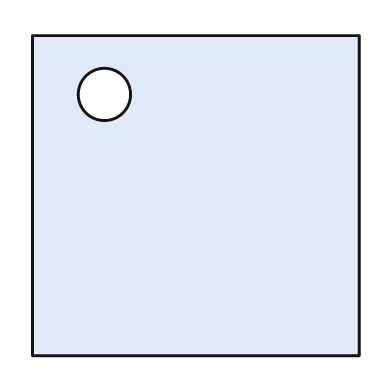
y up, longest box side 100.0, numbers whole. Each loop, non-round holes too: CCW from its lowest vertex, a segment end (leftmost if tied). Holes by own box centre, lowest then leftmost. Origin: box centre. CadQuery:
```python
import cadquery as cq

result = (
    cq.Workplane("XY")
    .moveTo(-50.0, -49.0)
    .lineTo(50.0, -49.0)
    .lineTo(50.0, 49.0)
    .lineTo(-50.0, 49.0)
    .close()
    .moveTo(-28.0, 31.0)
    .circle(8.0)
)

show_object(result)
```